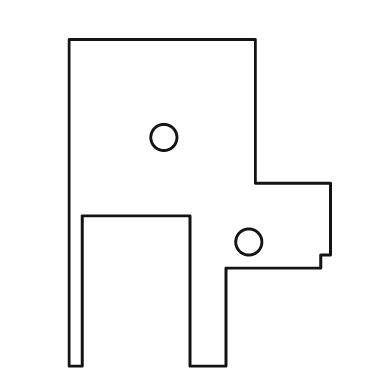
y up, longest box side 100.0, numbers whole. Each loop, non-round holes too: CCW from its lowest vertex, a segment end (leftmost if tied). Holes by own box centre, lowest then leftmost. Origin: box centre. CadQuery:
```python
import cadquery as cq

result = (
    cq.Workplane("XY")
    .moveTo(-40.0, -50.0)
    .lineTo(-36.0, -50.0)
    .lineTo(-36.0, -4.0)
    .lineTo(-3.0, -4.0)
    .lineTo(-3.0, -50.0)
    .lineTo(8.0, -50.0)
    .lineTo(8.0, -20.0)
    .lineTo(37.0, -20.0)
    .lineTo(37.0, -16.0)
    .lineTo(40.0, -16.0)
    .lineTo(40.0, 6.0)
    .lineTo(17.0, 6.0)
    .lineTo(17.0, 50.0)
    .lineTo(-40.0, 50.0)
    .close()
    .moveTo(15.0, -12.0)
    .circle(4.0)
    .moveTo(-11.0, 20.0)
    .circle(4.0)
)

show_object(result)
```